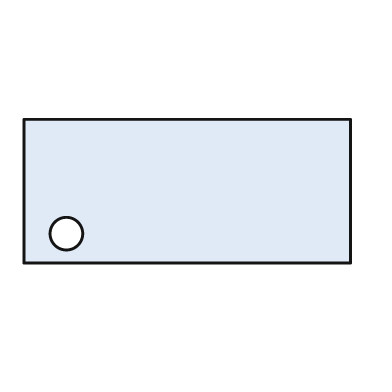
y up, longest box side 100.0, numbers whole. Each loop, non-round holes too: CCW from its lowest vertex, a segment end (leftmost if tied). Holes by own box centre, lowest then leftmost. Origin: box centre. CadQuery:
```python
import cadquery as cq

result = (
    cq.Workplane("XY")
    .moveTo(-50.0, -22.0)
    .lineTo(50.0, -22.0)
    .lineTo(50.0, 22.0)
    .lineTo(-50.0, 22.0)
    .close()
    .moveTo(-37.0, -13.0)
    .circle(5.0)
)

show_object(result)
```